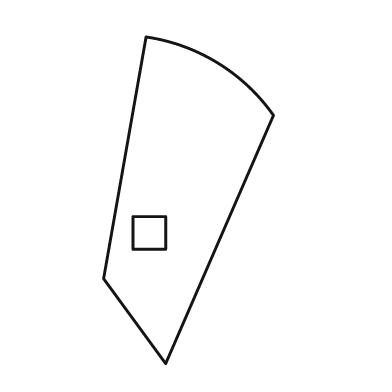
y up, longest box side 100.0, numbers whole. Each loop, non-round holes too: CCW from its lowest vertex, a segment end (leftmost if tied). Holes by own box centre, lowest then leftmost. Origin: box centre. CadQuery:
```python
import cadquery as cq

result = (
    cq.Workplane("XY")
    .moveTo(-7.0, -50.0)
    .lineTo(26.0, 26.0)
    .threePointArc((9.0, 42.0), (-13.0, 50.0))
    .lineTo(-26.0, -24.0)
    .close()
    .moveTo(-17.0, -15.0)
    .lineTo(-7.0, -15.0)
    .lineTo(-7.0, -5.0)
    .lineTo(-17.0, -5.0)
    .close()
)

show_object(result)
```